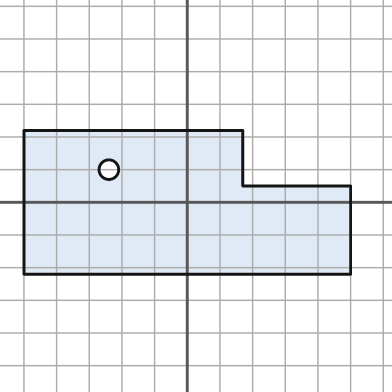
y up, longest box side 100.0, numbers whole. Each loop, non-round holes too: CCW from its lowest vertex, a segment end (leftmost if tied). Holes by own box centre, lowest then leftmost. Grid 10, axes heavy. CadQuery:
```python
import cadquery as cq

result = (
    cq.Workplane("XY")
    .moveTo(-50.0, -22.0)
    .lineTo(50.0, -22.0)
    .lineTo(50.0, 5.0)
    .lineTo(17.0, 5.0)
    .lineTo(17.0, 22.0)
    .lineTo(-50.0, 22.0)
    .close()
    .moveTo(-24.0, 10.0)
    .circle(3.0)
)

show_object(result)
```